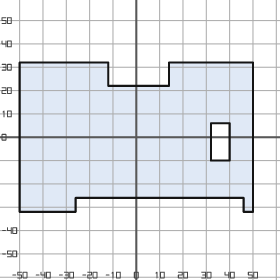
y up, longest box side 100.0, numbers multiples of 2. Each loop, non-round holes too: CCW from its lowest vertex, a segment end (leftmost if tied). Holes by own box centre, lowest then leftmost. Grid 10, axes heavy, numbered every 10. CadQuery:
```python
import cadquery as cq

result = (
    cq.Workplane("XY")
    .moveTo(-50.0, -32.0)
    .lineTo(-26.0, -32.0)
    .lineTo(-26.0, -26.0)
    .lineTo(46.0, -26.0)
    .lineTo(46.0, -32.0)
    .lineTo(50.0, -32.0)
    .lineTo(50.0, 32.0)
    .lineTo(14.0, 32.0)
    .lineTo(14.0, 22.0)
    .lineTo(-12.0, 22.0)
    .lineTo(-12.0, 32.0)
    .lineTo(-50.0, 32.0)
    .close()
    .moveTo(32.0, -10.0)
    .lineTo(40.0, -10.0)
    .lineTo(40.0, 6.0)
    .lineTo(32.0, 6.0)
    .close()
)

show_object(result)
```